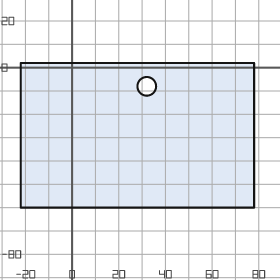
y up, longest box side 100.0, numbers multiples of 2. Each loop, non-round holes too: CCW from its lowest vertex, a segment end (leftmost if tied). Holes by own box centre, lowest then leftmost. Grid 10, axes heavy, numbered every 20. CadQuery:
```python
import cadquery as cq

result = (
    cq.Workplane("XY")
    .moveTo(-22.0, -60.0)
    .lineTo(78.0, -60.0)
    .lineTo(78.0, 2.0)
    .lineTo(-22.0, 2.0)
    .close()
    .moveTo(32.0, -8.0)
    .circle(4.0)
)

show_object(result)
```